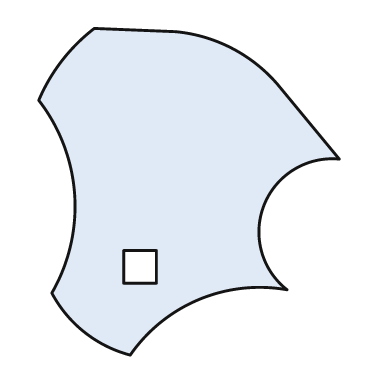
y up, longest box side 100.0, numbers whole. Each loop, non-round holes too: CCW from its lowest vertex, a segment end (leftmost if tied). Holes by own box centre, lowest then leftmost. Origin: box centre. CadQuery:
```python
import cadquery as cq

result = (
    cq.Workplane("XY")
    .moveTo(-18.0, -50.0)
    .threePointArc((3.0, -33.0), (30.0, -30.0))
    .threePointArc((23.0, -4.0), (46.0, 10.0))
    .lineTo(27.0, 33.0)
    .threePointArc((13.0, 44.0), (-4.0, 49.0))
    .lineTo(-29.0, 50.0)
    .threePointArc((-39.0, 40.0), (-46.0, 28.0))
    .threePointArc((-35.0, -1.0), (-42.0, -31.0))
    .threePointArc((-32.0, -43.0), (-18.0, -50.0))
    .close()
    .moveTo(-20.0, -28.0)
    .lineTo(-10.0, -28.0)
    .lineTo(-10.0, -18.0)
    .lineTo(-20.0, -18.0)
    .close()
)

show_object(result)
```